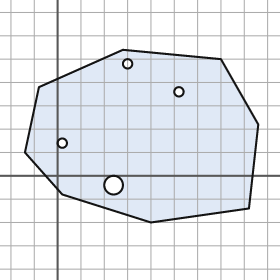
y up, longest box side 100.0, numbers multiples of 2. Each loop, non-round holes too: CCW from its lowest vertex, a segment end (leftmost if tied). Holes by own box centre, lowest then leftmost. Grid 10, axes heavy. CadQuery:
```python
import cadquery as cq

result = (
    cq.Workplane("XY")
    .moveTo(40.0, -20.0)
    .lineTo(82.0, -14.0)
    .lineTo(86.0, 22.0)
    .lineTo(70.0, 50.0)
    .lineTo(28.0, 54.0)
    .lineTo(-8.0, 38.0)
    .lineTo(-14.0, 10.0)
    .lineTo(2.0, -8.0)
    .close()
    .moveTo(24.0, -4.0)
    .circle(4.0)
    .moveTo(2.0, 14.0)
    .circle(2.0)
    .moveTo(52.0, 36.0)
    .circle(2.0)
    .moveTo(30.0, 48.0)
    .circle(2.0)
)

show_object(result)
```